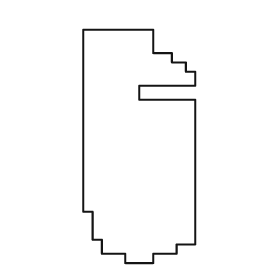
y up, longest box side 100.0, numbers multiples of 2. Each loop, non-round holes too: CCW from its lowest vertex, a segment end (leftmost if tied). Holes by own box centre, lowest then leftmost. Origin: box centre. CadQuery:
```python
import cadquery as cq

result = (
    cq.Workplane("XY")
    .moveTo(-6.0, -50.0)
    .lineTo(6.0, -50.0)
    .lineTo(6.0, -46.0)
    .lineTo(16.0, -46.0)
    .lineTo(16.0, -42.0)
    .lineTo(24.0, -42.0)
    .lineTo(24.0, 20.0)
    .lineTo(0.0, 20.0)
    .lineTo(0.0, 26.0)
    .lineTo(24.0, 26.0)
    .lineTo(24.0, 32.0)
    .lineTo(20.0, 32.0)
    .lineTo(20.0, 36.0)
    .lineTo(14.0, 36.0)
    .lineTo(14.0, 40.0)
    .lineTo(6.0, 40.0)
    .lineTo(6.0, 50.0)
    .lineTo(-24.0, 50.0)
    .lineTo(-24.0, -28.0)
    .lineTo(-20.0, -28.0)
    .lineTo(-20.0, -40.0)
    .lineTo(-16.0, -40.0)
    .lineTo(-16.0, -46.0)
    .lineTo(-6.0, -46.0)
    .close()
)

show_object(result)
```